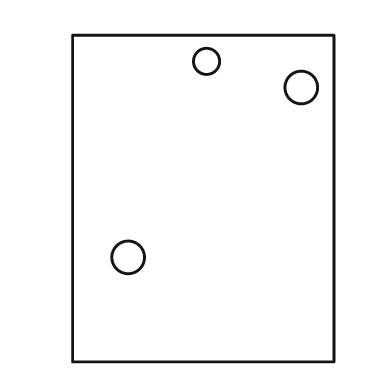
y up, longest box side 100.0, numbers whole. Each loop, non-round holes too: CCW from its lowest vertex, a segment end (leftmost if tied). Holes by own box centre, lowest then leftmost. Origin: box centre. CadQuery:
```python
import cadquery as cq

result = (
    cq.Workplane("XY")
    .moveTo(-40.0, -50.0)
    .lineTo(40.0, -50.0)
    .lineTo(40.0, 50.0)
    .lineTo(-40.0, 50.0)
    .close()
    .moveTo(-23.0, -18.0)
    .circle(5.0)
    .moveTo(30.0, 34.0)
    .circle(5.0)
    .moveTo(1.0, 42.0)
    .circle(4.0)
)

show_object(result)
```